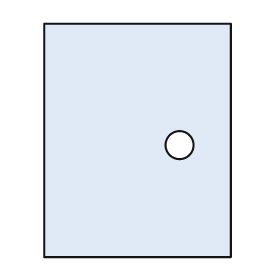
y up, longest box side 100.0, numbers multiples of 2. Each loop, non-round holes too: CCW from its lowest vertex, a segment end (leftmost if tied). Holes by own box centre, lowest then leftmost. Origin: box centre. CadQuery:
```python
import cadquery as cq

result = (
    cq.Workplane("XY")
    .moveTo(-40.0, -50.0)
    .lineTo(40.0, -50.0)
    .lineTo(40.0, 50.0)
    .lineTo(-40.0, 50.0)
    .close()
    .moveTo(18.0, -2.0)
    .circle(6.0)
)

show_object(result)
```